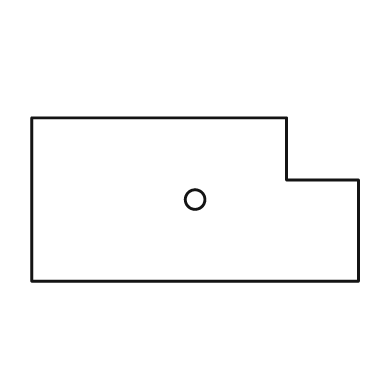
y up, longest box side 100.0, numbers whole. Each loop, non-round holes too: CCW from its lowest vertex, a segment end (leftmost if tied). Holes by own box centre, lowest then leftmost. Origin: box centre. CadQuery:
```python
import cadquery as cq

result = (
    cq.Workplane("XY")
    .moveTo(-50.0, -25.0)
    .lineTo(50.0, -25.0)
    .lineTo(50.0, 6.0)
    .lineTo(28.0, 6.0)
    .lineTo(28.0, 25.0)
    .lineTo(-50.0, 25.0)
    .close()
    .moveTo(0.0, 0.0)
    .circle(3.0)
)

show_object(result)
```